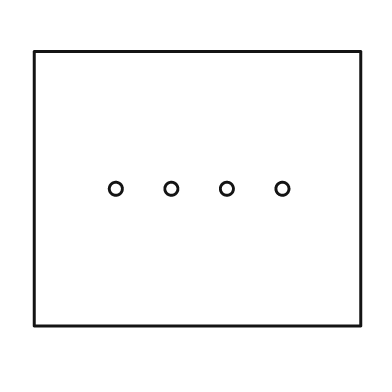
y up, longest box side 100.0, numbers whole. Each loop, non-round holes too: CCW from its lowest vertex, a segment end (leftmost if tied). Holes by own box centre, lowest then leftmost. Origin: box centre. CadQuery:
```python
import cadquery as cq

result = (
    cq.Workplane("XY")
    .moveTo(-50.0, -42.0)
    .lineTo(50.0, -42.0)
    .lineTo(50.0, 42.0)
    .lineTo(-50.0, 42.0)
    .close()
    .moveTo(-25.0, 0.0)
    .circle(2.0)
    .moveTo(-8.0, 0.0)
    .circle(2.0)
    .moveTo(9.0, 0.0)
    .circle(2.0)
    .moveTo(26.0, 0.0)
    .circle(2.0)
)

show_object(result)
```